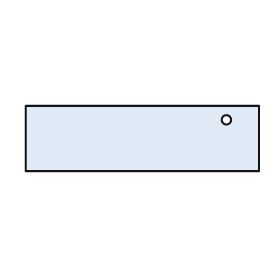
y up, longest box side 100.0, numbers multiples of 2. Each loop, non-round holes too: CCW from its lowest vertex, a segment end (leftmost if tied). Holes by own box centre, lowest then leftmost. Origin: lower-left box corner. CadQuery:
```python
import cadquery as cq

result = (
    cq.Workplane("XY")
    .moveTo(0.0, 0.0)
    .lineTo(100.0, 0.0)
    .lineTo(100.0, 28.0)
    .lineTo(0.0, 28.0)
    .close()
    .moveTo(86.0, 22.0)
    .circle(2.0)
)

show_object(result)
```